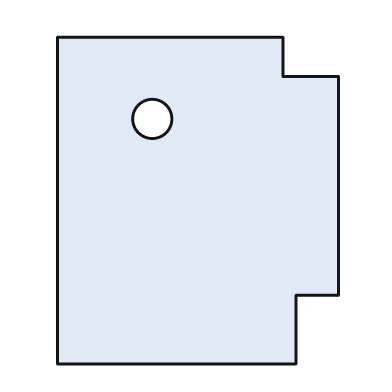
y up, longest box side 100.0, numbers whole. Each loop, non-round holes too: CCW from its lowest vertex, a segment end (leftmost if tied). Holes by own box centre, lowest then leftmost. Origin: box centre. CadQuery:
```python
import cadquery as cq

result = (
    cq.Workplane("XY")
    .moveTo(-43.0, -50.0)
    .lineTo(30.0, -50.0)
    .lineTo(30.0, -29.0)
    .lineTo(43.0, -29.0)
    .lineTo(43.0, 38.0)
    .lineTo(26.0, 38.0)
    .lineTo(26.0, 50.0)
    .lineTo(-43.0, 50.0)
    .close()
    .moveTo(-14.0, 25.0)
    .circle(6.0)
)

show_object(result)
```